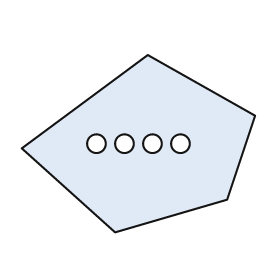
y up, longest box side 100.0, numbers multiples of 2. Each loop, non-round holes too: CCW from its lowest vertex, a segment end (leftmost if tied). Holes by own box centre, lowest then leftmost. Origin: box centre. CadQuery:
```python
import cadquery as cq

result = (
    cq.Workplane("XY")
    .moveTo(-10.0, -38.0)
    .lineTo(38.0, -24.0)
    .lineTo(50.0, 12.0)
    .lineTo(4.0, 38.0)
    .lineTo(-50.0, -2.0)
    .close()
    .moveTo(-18.0, 0.0)
    .circle(4.0)
    .moveTo(-6.0, 0.0)
    .circle(4.0)
    .moveTo(6.0, 0.0)
    .circle(4.0)
    .moveTo(18.0, 0.0)
    .circle(4.0)
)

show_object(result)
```